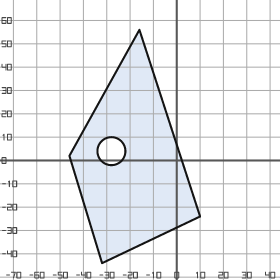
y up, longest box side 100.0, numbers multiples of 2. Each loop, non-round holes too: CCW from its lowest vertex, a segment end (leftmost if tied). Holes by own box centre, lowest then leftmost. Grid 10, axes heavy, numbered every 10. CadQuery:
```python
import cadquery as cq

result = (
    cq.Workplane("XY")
    .moveTo(-32.0, -44.0)
    .lineTo(10.0, -24.0)
    .lineTo(-16.0, 56.0)
    .lineTo(-46.0, 2.0)
    .close()
    .moveTo(-28.0, 4.0)
    .circle(6.0)
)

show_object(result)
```